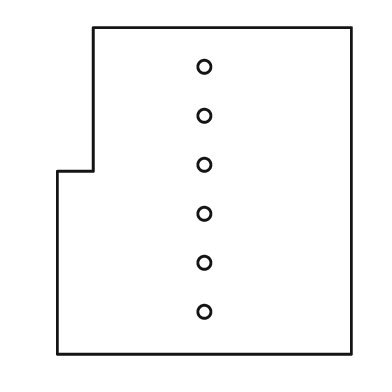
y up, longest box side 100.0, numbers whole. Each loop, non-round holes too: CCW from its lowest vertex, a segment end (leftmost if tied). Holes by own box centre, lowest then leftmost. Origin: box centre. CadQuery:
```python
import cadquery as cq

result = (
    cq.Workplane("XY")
    .moveTo(-45.0, -50.0)
    .lineTo(45.0, -50.0)
    .lineTo(45.0, 50.0)
    .lineTo(-34.0, 50.0)
    .lineTo(-34.0, 6.0)
    .lineTo(-45.0, 6.0)
    .close()
    .moveTo(0.0, -37.0)
    .circle(2.0)
    .moveTo(0.0, -22.0)
    .circle(2.0)
    .moveTo(0.0, -7.0)
    .circle(2.0)
    .moveTo(0.0, 8.0)
    .circle(2.0)
    .moveTo(0.0, 23.0)
    .circle(2.0)
    .moveTo(0.0, 38.0)
    .circle(2.0)
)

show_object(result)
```